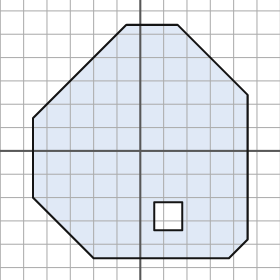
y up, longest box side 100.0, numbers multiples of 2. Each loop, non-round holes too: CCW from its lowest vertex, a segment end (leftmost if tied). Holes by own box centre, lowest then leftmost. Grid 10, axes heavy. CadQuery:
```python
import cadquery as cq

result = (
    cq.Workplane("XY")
    .moveTo(-20.0, -46.0)
    .lineTo(38.0, -46.0)
    .lineTo(46.0, -38.0)
    .lineTo(46.0, 24.0)
    .lineTo(16.0, 54.0)
    .lineTo(-6.0, 54.0)
    .lineTo(-46.0, 14.0)
    .lineTo(-46.0, -20.0)
    .close()
    .moveTo(6.0, -34.0)
    .lineTo(18.0, -34.0)
    .lineTo(18.0, -22.0)
    .lineTo(6.0, -22.0)
    .close()
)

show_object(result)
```